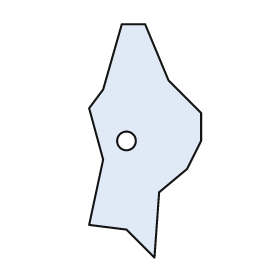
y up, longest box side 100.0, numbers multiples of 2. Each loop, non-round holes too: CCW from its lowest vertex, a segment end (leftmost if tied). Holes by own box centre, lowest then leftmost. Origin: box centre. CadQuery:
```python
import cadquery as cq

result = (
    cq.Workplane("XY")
    .moveTo(4.0, -50.0)
    .lineTo(6.0, -22.0)
    .lineTo(18.0, -12.0)
    .lineTo(24.0, 0.0)
    .lineTo(24.0, 12.0)
    .lineTo(10.0, 26.0)
    .lineTo(0.0, 50.0)
    .lineTo(-10.0, 50.0)
    .lineTo(-18.0, 22.0)
    .lineTo(-24.0, 14.0)
    .lineTo(-18.0, -8.0)
    .lineTo(-24.0, -36.0)
    .lineTo(-8.0, -38.0)
    .close()
    .moveTo(-8.0, 0.0)
    .circle(4.0)
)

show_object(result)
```